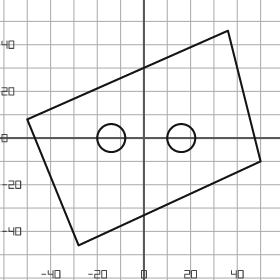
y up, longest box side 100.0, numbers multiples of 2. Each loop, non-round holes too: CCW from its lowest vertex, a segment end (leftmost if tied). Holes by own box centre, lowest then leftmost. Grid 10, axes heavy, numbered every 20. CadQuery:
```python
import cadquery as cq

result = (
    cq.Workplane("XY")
    .moveTo(-28.0, -46.0)
    .lineTo(50.0, -10.0)
    .lineTo(36.0, 46.0)
    .lineTo(-50.0, 8.0)
    .close()
    .moveTo(-14.0, 0.0)
    .circle(6.0)
    .moveTo(16.0, 0.0)
    .circle(6.0)
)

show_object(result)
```